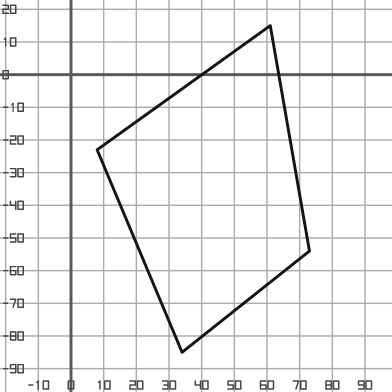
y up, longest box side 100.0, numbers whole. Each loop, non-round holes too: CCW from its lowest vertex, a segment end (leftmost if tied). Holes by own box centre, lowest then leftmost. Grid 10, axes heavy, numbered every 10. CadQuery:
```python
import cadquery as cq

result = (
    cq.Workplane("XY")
    .moveTo(34.0, -85.0)
    .lineTo(73.0, -54.0)
    .lineTo(61.0, 15.0)
    .lineTo(8.0, -23.0)
    .close()
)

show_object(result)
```